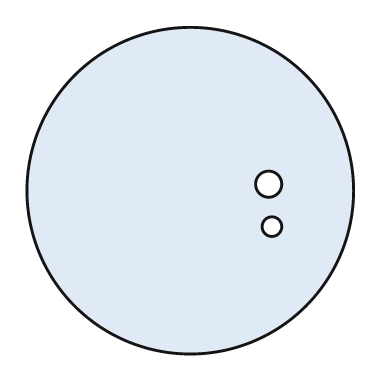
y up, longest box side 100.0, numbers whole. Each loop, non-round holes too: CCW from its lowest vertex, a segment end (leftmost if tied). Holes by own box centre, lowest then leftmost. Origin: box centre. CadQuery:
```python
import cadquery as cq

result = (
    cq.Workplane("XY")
    .moveTo(0.0, 0.0)
    .circle(50.0)
    .moveTo(25.0, -11.0)
    .circle(3.0)
    .moveTo(24.0, 2.0)
    .circle(4.0)
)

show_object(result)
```